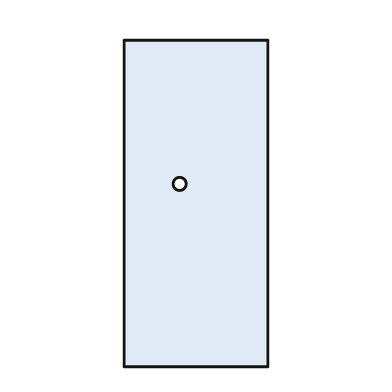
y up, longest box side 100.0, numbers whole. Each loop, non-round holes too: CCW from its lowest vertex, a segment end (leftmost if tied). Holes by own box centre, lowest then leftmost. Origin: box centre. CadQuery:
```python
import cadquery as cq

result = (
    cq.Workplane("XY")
    .moveTo(-22.0, -50.0)
    .lineTo(22.0, -50.0)
    .lineTo(22.0, 50.0)
    .lineTo(-22.0, 50.0)
    .close()
    .moveTo(-5.0, 6.0)
    .circle(2.0)
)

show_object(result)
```